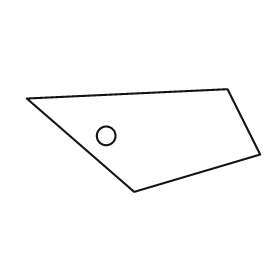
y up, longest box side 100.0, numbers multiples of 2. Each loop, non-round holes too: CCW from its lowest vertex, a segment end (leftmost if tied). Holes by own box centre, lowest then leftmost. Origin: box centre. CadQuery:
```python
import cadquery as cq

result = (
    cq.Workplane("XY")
    .moveTo(-4.0, -22.0)
    .lineTo(50.0, -6.0)
    .lineTo(36.0, 22.0)
    .lineTo(-50.0, 18.0)
    .close()
    .moveTo(-16.0, 2.0)
    .circle(4.0)
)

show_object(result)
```